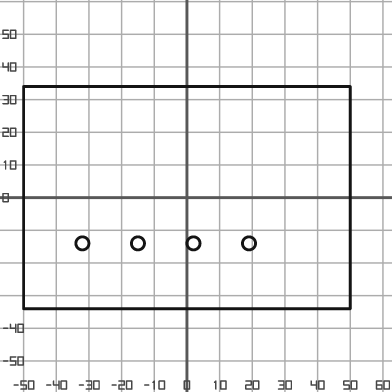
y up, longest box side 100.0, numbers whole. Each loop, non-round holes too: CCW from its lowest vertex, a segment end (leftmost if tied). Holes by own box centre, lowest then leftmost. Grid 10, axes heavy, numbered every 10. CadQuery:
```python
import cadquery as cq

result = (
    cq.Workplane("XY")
    .moveTo(-50.0, -34.0)
    .lineTo(50.0, -34.0)
    .lineTo(50.0, 34.0)
    .lineTo(-50.0, 34.0)
    .close()
    .moveTo(-32.0, -14.0)
    .circle(2.0)
    .moveTo(-15.0, -14.0)
    .circle(2.0)
    .moveTo(2.0, -14.0)
    .circle(2.0)
    .moveTo(19.0, -14.0)
    .circle(2.0)
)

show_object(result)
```